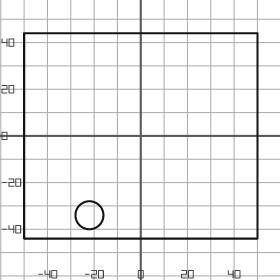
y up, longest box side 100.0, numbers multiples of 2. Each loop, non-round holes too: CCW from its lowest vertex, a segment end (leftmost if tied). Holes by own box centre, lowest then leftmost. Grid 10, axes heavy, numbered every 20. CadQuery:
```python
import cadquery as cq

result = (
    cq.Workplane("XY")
    .moveTo(-50.0, -44.0)
    .lineTo(50.0, -44.0)
    .lineTo(50.0, 44.0)
    .lineTo(-50.0, 44.0)
    .close()
    .moveTo(-22.0, -34.0)
    .circle(6.0)
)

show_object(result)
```